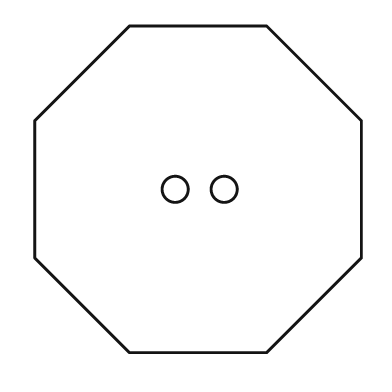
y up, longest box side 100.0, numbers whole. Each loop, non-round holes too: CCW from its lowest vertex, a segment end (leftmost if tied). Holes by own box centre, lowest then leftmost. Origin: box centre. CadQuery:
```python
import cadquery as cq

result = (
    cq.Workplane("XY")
    .moveTo(-21.0, -50.0)
    .lineTo(21.0, -50.0)
    .lineTo(50.0, -21.0)
    .lineTo(50.0, 21.0)
    .lineTo(21.0, 50.0)
    .lineTo(-21.0, 50.0)
    .lineTo(-50.0, 21.0)
    .lineTo(-50.0, -21.0)
    .close()
    .moveTo(-7.0, 0.0)
    .circle(4.0)
    .moveTo(8.0, 0.0)
    .circle(4.0)
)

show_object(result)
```